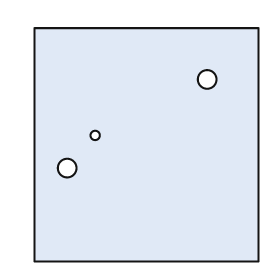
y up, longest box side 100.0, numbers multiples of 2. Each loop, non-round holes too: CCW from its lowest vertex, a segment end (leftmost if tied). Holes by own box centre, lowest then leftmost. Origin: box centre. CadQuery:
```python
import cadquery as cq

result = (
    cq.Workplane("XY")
    .moveTo(-48.0, -50.0)
    .lineTo(48.0, -50.0)
    .lineTo(48.0, 50.0)
    .lineTo(-48.0, 50.0)
    .close()
    .moveTo(-34.0, -10.0)
    .circle(4.0)
    .moveTo(-22.0, 4.0)
    .circle(2.0)
    .moveTo(26.0, 28.0)
    .circle(4.0)
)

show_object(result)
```